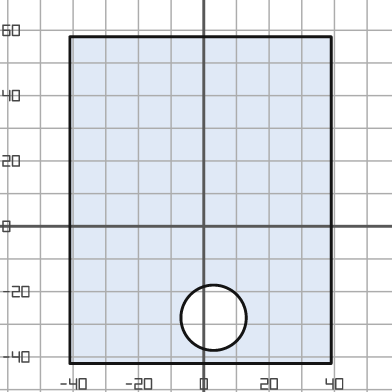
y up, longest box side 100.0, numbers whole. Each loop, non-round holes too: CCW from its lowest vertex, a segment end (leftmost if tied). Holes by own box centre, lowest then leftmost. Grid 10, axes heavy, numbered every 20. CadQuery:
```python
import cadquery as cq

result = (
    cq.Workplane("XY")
    .moveTo(-41.0, -42.0)
    .lineTo(39.0, -42.0)
    .lineTo(39.0, 58.0)
    .lineTo(-41.0, 58.0)
    .close()
    .moveTo(3.0, -28.0)
    .circle(10.0)
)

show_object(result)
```